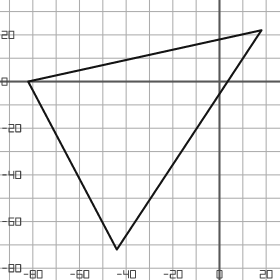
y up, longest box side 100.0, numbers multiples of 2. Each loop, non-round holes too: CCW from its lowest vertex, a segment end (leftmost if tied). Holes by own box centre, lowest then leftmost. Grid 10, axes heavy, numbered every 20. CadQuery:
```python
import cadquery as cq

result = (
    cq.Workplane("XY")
    .moveTo(-44.0, -72.0)
    .lineTo(18.0, 22.0)
    .lineTo(-82.0, 0.0)
    .close()
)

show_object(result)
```